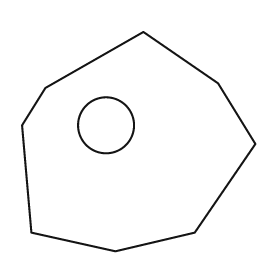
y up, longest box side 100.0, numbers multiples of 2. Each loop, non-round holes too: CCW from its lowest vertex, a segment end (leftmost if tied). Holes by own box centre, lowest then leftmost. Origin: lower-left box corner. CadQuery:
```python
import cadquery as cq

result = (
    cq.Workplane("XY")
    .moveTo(40.0, 0.0)
    .lineTo(74.0, 8.0)
    .lineTo(100.0, 46.0)
    .lineTo(84.0, 72.0)
    .lineTo(52.0, 94.0)
    .lineTo(10.0, 70.0)
    .lineTo(0.0, 54.0)
    .lineTo(4.0, 8.0)
    .close()
    .moveTo(36.0, 54.0)
    .circle(12.0)
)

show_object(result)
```